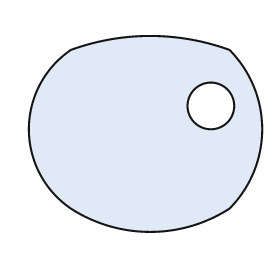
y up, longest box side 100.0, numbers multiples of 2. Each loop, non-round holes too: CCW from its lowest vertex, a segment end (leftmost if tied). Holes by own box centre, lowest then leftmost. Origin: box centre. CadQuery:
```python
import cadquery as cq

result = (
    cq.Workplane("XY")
    .moveTo(-32.0, -32.0)
    .threePointArc((2.0, -42.0), (36.0, -32.0))
    .threePointArc((50.0, 2.0), (36.0, 36.0))
    .threePointArc((2.0, 42.0), (-32.0, 36.0))
    .threePointArc((-50.0, 2.0), (-32.0, -32.0))
    .close()
    .moveTo(28.0, 12.0)
    .circle(10.0)
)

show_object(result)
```